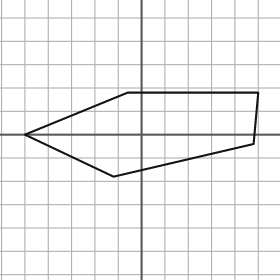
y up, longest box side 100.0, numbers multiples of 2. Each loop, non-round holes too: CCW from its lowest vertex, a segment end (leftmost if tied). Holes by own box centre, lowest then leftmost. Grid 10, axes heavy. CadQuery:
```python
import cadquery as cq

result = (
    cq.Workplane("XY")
    .moveTo(-12.0, -18.0)
    .lineTo(48.0, -4.0)
    .lineTo(50.0, 18.0)
    .lineTo(-6.0, 18.0)
    .lineTo(-50.0, 0.0)
    .close()
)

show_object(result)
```